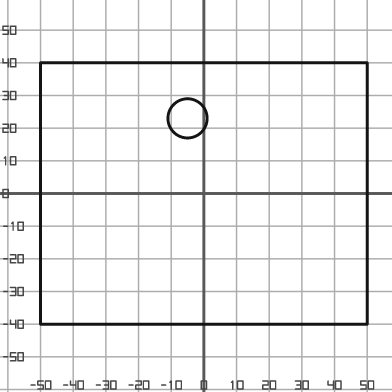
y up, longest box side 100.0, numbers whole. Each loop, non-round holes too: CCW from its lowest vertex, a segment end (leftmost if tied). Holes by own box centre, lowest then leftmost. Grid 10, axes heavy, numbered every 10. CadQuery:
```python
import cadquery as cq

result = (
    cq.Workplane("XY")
    .moveTo(-50.0, -40.0)
    .lineTo(50.0, -40.0)
    .lineTo(50.0, 40.0)
    .lineTo(-50.0, 40.0)
    .close()
    .moveTo(-5.0, 23.0)
    .circle(6.0)
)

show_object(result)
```